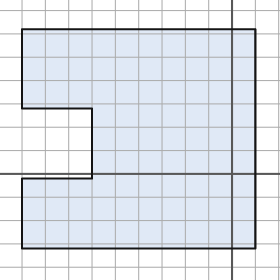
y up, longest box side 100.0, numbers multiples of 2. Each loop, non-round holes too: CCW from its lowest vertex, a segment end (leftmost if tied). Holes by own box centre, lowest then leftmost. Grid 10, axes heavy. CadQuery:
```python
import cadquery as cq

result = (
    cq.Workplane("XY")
    .moveTo(-90.0, -32.0)
    .lineTo(10.0, -32.0)
    .lineTo(10.0, 62.0)
    .lineTo(-90.0, 62.0)
    .lineTo(-90.0, 28.0)
    .lineTo(-60.0, 28.0)
    .lineTo(-60.0, -2.0)
    .lineTo(-90.0, -2.0)
    .close()
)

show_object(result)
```